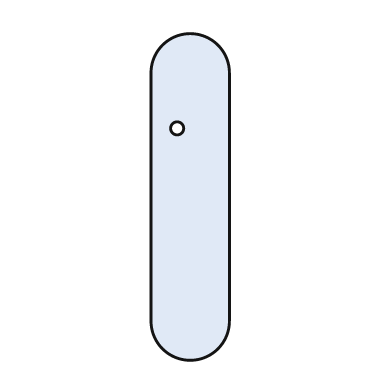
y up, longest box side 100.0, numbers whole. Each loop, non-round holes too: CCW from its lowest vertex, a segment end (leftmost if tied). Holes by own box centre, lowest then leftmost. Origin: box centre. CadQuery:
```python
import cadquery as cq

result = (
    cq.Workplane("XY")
    .moveTo(-12.0, -38.0)
    .threePointArc((0.0, -50.0), (12.0, -38.0))
    .lineTo(12.0, 38.0)
    .threePointArc((0.0, 50.0), (-12.0, 38.0))
    .close()
    .moveTo(-4.0, 21.0)
    .circle(2.0)
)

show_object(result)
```